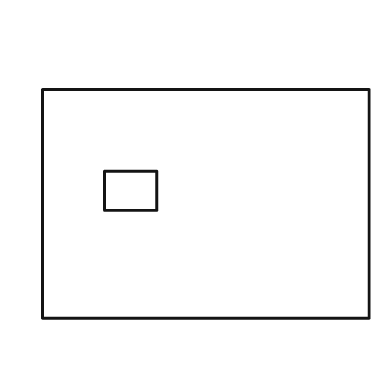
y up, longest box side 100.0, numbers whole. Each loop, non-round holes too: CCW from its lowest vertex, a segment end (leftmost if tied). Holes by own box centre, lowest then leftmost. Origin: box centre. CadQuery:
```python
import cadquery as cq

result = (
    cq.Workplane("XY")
    .moveTo(-50.0, -35.0)
    .lineTo(50.0, -35.0)
    .lineTo(50.0, 35.0)
    .lineTo(-50.0, 35.0)
    .close()
    .moveTo(-31.0, -2.0)
    .lineTo(-15.0, -2.0)
    .lineTo(-15.0, 10.0)
    .lineTo(-31.0, 10.0)
    .close()
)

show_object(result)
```